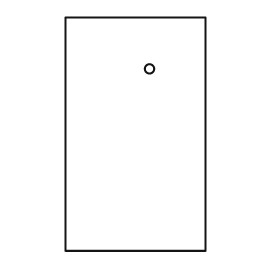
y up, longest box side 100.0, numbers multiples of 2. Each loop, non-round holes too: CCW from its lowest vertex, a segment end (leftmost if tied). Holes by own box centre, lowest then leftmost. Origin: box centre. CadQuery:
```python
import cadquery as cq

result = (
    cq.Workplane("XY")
    .moveTo(-30.0, -50.0)
    .lineTo(30.0, -50.0)
    .lineTo(30.0, 50.0)
    .lineTo(-30.0, 50.0)
    .close()
    .moveTo(6.0, 28.0)
    .circle(2.0)
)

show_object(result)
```